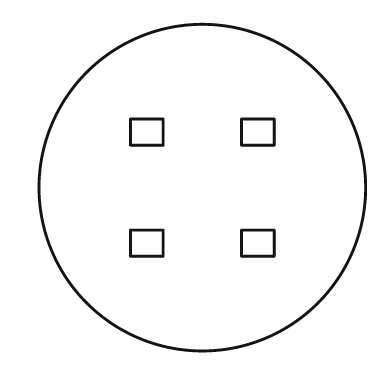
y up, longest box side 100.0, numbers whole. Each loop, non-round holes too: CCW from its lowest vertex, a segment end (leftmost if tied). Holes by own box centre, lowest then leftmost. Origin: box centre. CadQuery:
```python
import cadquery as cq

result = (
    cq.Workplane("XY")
    .moveTo(0.0, 0.0)
    .circle(50.0)
    .moveTo(-22.0, -21.0)
    .lineTo(-12.0, -21.0)
    .lineTo(-12.0, -13.0)
    .lineTo(-22.0, -13.0)
    .close()
    .moveTo(12.0, -21.0)
    .lineTo(22.0, -21.0)
    .lineTo(22.0, -13.0)
    .lineTo(12.0, -13.0)
    .close()
    .moveTo(-22.0, 13.0)
    .lineTo(-12.0, 13.0)
    .lineTo(-12.0, 21.0)
    .lineTo(-22.0, 21.0)
    .close()
    .moveTo(12.0, 13.0)
    .lineTo(22.0, 13.0)
    .lineTo(22.0, 21.0)
    .lineTo(12.0, 21.0)
    .close()
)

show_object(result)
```